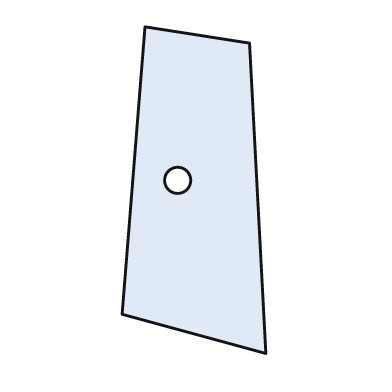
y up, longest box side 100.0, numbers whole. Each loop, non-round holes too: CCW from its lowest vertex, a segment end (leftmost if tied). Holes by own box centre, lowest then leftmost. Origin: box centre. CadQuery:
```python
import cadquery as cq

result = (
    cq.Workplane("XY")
    .moveTo(22.0, -50.0)
    .lineTo(17.0, 45.0)
    .lineTo(-15.0, 50.0)
    .lineTo(-22.0, -38.0)
    .close()
    .moveTo(-5.0, 3.0)
    .circle(4.0)
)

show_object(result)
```